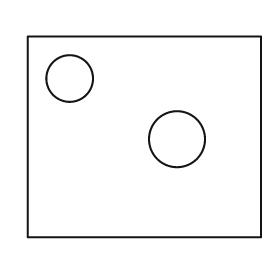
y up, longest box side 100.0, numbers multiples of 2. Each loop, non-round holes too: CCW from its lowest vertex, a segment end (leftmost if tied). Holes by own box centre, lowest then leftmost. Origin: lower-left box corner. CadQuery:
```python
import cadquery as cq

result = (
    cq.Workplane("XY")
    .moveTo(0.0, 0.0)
    .lineTo(100.0, 0.0)
    .lineTo(100.0, 86.0)
    .lineTo(0.0, 86.0)
    .close()
    .moveTo(64.0, 42.0)
    .circle(12.0)
    .moveTo(18.0, 68.0)
    .circle(10.0)
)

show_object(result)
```